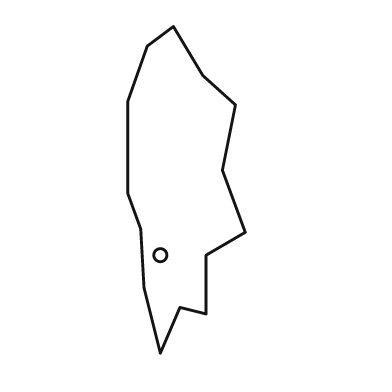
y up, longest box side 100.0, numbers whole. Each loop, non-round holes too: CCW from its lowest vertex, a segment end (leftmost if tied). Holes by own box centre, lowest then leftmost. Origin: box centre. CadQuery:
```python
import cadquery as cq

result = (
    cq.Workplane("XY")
    .moveTo(-8.0, -50.0)
    .lineTo(-2.0, -36.0)
    .lineTo(6.0, -38.0)
    .lineTo(6.0, -20.0)
    .lineTo(18.0, -13.0)
    .lineTo(11.0, 6.0)
    .lineTo(15.0, 26.0)
    .lineTo(5.0, 35.0)
    .lineTo(-4.0, 50.0)
    .lineTo(-12.0, 44.0)
    .lineTo(-18.0, 27.0)
    .lineTo(-18.0, -1.0)
    .lineTo(-14.0, -12.0)
    .lineTo(-13.0, -30.0)
    .close()
    .moveTo(-8.0, -20.0)
    .circle(2.0)
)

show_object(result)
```